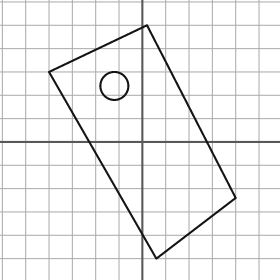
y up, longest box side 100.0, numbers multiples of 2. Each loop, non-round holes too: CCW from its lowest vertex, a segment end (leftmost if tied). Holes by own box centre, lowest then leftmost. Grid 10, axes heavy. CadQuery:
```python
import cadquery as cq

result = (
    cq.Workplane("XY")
    .moveTo(6.0, -50.0)
    .lineTo(40.0, -24.0)
    .lineTo(2.0, 50.0)
    .lineTo(-40.0, 30.0)
    .close()
    .moveTo(-12.0, 24.0)
    .circle(6.0)
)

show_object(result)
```